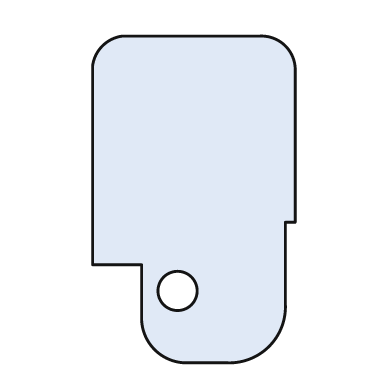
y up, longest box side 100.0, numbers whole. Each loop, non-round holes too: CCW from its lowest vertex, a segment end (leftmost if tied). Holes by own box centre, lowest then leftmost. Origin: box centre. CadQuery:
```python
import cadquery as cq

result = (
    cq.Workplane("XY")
    .moveTo(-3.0, -50.0)
    .lineTo(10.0, -50.0)
    .threePointArc((23.0, -45.0), (28.0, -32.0))
    .lineTo(28.0, -7.0)
    .lineTo(31.0, -7.0)
    .lineTo(31.0, 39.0)
    .threePointArc((28.0, 47.0), (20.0, 50.0))
    .lineTo(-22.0, 50.0)
    .threePointArc((-28.0, 47.0), (-31.0, 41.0))
    .lineTo(-31.0, -20.0)
    .lineTo(-16.0, -20.0)
    .lineTo(-16.0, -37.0)
    .threePointArc((-12.0, -46.0), (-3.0, -50.0))
    .close()
    .moveTo(-5.0, -28.0)
    .circle(6.0)
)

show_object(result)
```